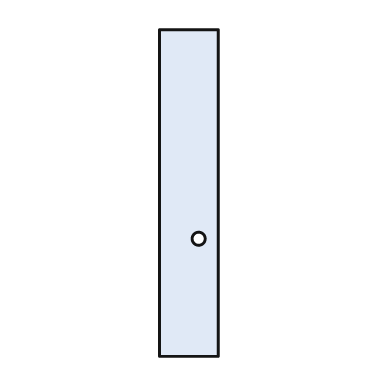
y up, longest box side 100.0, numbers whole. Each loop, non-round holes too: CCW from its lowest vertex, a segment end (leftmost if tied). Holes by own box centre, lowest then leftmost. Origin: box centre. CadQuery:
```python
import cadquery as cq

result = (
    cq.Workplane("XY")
    .moveTo(-9.0, -50.0)
    .lineTo(9.0, -50.0)
    .lineTo(9.0, 50.0)
    .lineTo(-9.0, 50.0)
    .close()
    .moveTo(3.0, -14.0)
    .circle(2.0)
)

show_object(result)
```